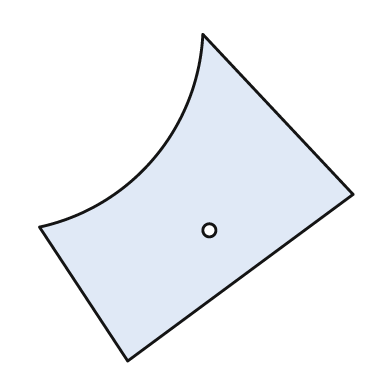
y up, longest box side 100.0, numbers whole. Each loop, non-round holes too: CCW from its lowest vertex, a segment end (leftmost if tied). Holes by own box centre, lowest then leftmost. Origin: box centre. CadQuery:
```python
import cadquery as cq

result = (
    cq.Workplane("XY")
    .moveTo(-21.0, -50.0)
    .lineTo(48.0, 1.0)
    .lineTo(2.0, 50.0)
    .threePointArc((-13.0, 12.0), (-48.0, -9.0))
    .close()
    .moveTo(4.0, -10.0)
    .circle(2.0)
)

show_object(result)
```